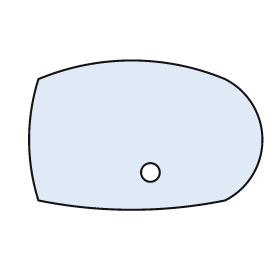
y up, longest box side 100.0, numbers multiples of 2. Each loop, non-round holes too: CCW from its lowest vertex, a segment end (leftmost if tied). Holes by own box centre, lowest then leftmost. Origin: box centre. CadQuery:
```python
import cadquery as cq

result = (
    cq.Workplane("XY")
    .moveTo(-46.0, -28.0)
    .threePointArc((-6.0, -32.0), (34.0, -28.0))
    .threePointArc((50.0, -2.0), (34.0, 24.0))
    .threePointArc((-6.0, 32.0), (-46.0, 24.0))
    .threePointArc((-50.0, -2.0), (-46.0, -28.0))
    .close()
    .moveTo(2.0, -16.0)
    .circle(4.0)
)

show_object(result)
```